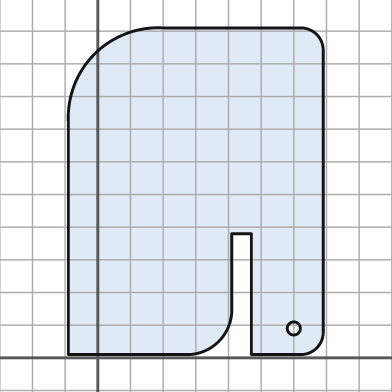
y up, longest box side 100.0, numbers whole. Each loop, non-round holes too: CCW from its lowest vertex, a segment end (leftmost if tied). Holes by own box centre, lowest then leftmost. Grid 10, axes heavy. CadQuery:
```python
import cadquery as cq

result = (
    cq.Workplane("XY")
    .moveTo(-9.0, 1.0)
    .lineTo(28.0, 1.0)
    .threePointArc((37.0, 5.0), (41.0, 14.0))
    .lineTo(41.0, 38.0)
    .lineTo(47.0, 38.0)
    .lineTo(47.0, 1.0)
    .lineTo(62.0, 1.0)
    .threePointArc((67.0, 3.0), (69.0, 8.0))
    .lineTo(69.0, 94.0)
    .threePointArc((67.0, 99.0), (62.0, 101.0))
    .lineTo(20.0, 101.0)
    .threePointArc((-1.0, 93.0), (-9.0, 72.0))
    .close()
    .moveTo(60.0, 9.0)
    .circle(2.0)
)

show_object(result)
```